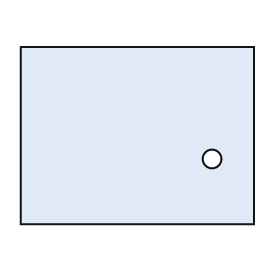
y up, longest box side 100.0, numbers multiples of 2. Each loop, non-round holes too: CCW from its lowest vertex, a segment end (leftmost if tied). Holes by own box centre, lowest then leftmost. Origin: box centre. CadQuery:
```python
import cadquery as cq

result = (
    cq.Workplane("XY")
    .moveTo(-50.0, -38.0)
    .lineTo(50.0, -38.0)
    .lineTo(50.0, 38.0)
    .lineTo(-50.0, 38.0)
    .close()
    .moveTo(32.0, -10.0)
    .circle(4.0)
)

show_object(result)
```